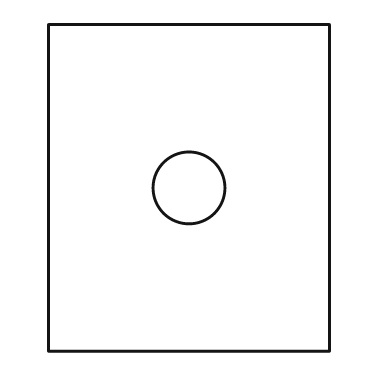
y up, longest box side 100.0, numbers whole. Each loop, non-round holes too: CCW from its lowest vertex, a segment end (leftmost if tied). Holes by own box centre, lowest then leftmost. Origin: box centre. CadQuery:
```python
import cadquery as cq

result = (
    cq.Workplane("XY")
    .moveTo(-43.0, -50.0)
    .lineTo(43.0, -50.0)
    .lineTo(43.0, 50.0)
    .lineTo(-43.0, 50.0)
    .close()
    .moveTo(0.0, 0.0)
    .circle(11.0)
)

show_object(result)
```